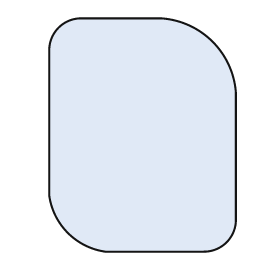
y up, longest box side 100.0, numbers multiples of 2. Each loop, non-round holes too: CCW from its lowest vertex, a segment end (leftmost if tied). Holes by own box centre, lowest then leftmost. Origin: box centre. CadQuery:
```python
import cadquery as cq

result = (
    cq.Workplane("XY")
    .moveTo(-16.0, -50.0)
    .lineTo(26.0, -50.0)
    .threePointArc((36.0, -46.0), (40.0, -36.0))
    .lineTo(40.0, 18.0)
    .threePointArc((30.0, 40.0), (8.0, 50.0))
    .lineTo(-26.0, 50.0)
    .threePointArc((-36.0, 46.0), (-40.0, 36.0))
    .lineTo(-40.0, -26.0)
    .threePointArc((-32.0, -42.0), (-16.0, -50.0))
    .close()
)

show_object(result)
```